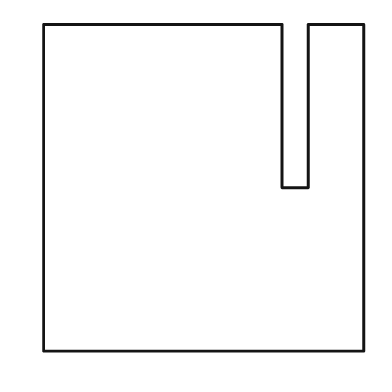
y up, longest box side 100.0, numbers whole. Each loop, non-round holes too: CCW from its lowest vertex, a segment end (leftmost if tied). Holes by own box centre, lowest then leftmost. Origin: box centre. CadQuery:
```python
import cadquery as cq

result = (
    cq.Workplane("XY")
    .moveTo(-49.0, -50.0)
    .lineTo(49.0, -50.0)
    .lineTo(49.0, 50.0)
    .lineTo(32.0, 50.0)
    .lineTo(32.0, 0.0)
    .lineTo(24.0, 0.0)
    .lineTo(24.0, 50.0)
    .lineTo(-49.0, 50.0)
    .close()
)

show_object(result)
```